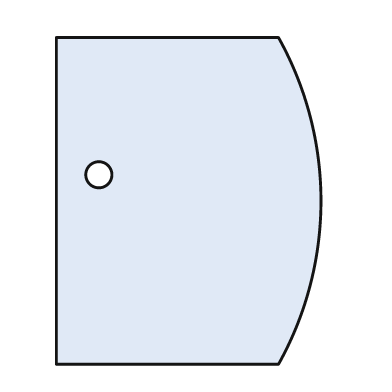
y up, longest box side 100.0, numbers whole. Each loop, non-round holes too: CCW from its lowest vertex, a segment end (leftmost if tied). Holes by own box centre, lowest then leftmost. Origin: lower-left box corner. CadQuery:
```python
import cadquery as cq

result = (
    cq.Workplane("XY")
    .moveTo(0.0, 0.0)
    .lineTo(68.0, 0.0)
    .threePointArc((81.0, 50.0), (68.0, 100.0))
    .lineTo(0.0, 100.0)
    .close()
    .moveTo(13.0, 58.0)
    .circle(4.0)
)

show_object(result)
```